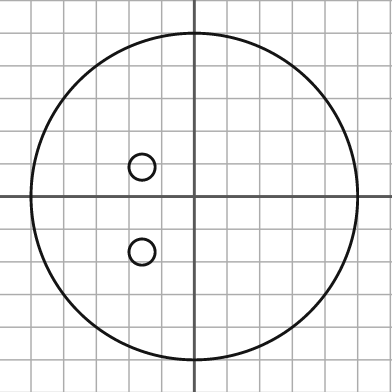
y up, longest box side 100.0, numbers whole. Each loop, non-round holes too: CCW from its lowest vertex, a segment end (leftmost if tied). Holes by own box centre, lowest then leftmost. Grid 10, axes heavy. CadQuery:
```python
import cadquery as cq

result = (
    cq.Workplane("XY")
    .moveTo(0.0, 0.0)
    .circle(50.0)
    .moveTo(-16.0, -17.0)
    .circle(4.0)
    .moveTo(-16.0, 9.0)
    .circle(4.0)
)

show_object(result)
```